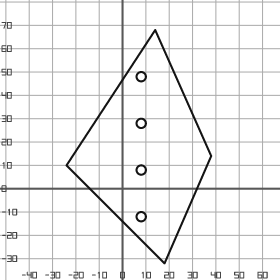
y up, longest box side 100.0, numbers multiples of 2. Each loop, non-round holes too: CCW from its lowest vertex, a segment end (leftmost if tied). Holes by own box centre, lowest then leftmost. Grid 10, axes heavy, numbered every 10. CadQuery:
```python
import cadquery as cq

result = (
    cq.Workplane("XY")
    .moveTo(18.0, -32.0)
    .lineTo(38.0, 14.0)
    .lineTo(14.0, 68.0)
    .lineTo(-24.0, 10.0)
    .close()
    .moveTo(8.0, -12.0)
    .circle(2.0)
    .moveTo(8.0, 8.0)
    .circle(2.0)
    .moveTo(8.0, 28.0)
    .circle(2.0)
    .moveTo(8.0, 48.0)
    .circle(2.0)
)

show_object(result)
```